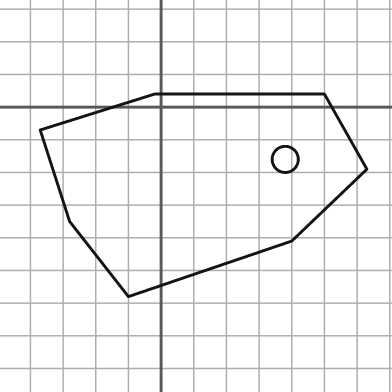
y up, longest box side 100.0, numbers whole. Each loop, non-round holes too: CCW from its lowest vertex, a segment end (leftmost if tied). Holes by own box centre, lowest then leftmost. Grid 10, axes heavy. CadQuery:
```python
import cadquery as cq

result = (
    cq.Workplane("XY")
    .moveTo(-10.0, -58.0)
    .lineTo(40.0, -41.0)
    .lineTo(63.0, -19.0)
    .lineTo(50.0, 4.0)
    .lineTo(-2.0, 4.0)
    .lineTo(-37.0, -7.0)
    .lineTo(-28.0, -35.0)
    .close()
    .moveTo(38.0, -16.0)
    .circle(4.0)
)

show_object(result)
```